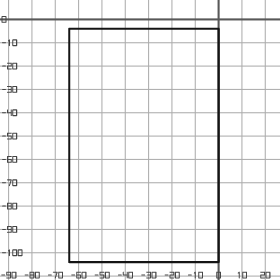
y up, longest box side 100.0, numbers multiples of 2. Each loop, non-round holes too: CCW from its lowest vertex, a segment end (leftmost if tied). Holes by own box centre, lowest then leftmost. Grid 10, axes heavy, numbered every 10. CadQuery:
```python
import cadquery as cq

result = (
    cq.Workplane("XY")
    .moveTo(-64.0, -104.0)
    .lineTo(0.0, -104.0)
    .lineTo(0.0, -4.0)
    .lineTo(-64.0, -4.0)
    .close()
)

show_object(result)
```